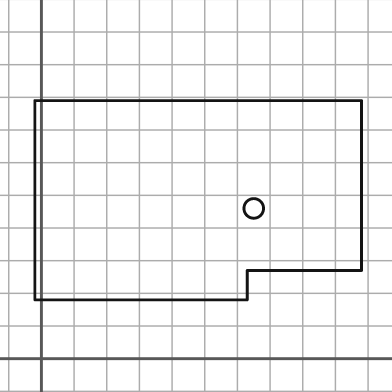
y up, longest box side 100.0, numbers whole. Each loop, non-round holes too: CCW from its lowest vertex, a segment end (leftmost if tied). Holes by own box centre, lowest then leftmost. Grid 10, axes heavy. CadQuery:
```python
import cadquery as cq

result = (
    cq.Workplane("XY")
    .moveTo(-2.0, 18.0)
    .lineTo(63.0, 18.0)
    .lineTo(63.0, 27.0)
    .lineTo(98.0, 27.0)
    .lineTo(98.0, 79.0)
    .lineTo(-2.0, 79.0)
    .close()
    .moveTo(65.0, 46.0)
    .circle(3.0)
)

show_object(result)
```